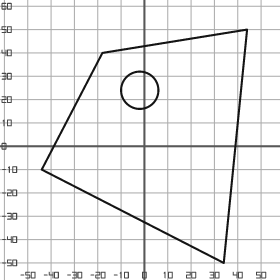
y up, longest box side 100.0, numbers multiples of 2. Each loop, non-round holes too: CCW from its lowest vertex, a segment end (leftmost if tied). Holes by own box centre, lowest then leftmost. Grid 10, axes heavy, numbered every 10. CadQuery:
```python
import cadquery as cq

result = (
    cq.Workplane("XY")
    .moveTo(34.0, -50.0)
    .lineTo(44.0, 50.0)
    .lineTo(-18.0, 40.0)
    .lineTo(-44.0, -10.0)
    .close()
    .moveTo(-2.0, 24.0)
    .circle(8.0)
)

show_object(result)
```